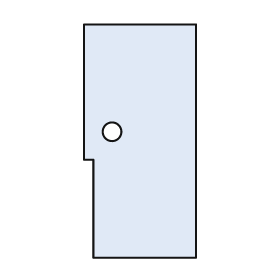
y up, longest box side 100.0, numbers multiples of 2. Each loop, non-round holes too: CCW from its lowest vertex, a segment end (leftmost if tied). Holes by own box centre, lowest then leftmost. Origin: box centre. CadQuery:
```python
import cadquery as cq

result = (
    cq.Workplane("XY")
    .moveTo(-20.0, -50.0)
    .lineTo(24.0, -50.0)
    .lineTo(24.0, 50.0)
    .lineTo(-24.0, 50.0)
    .lineTo(-24.0, -8.0)
    .lineTo(-20.0, -8.0)
    .close()
    .moveTo(-12.0, 4.0)
    .circle(4.0)
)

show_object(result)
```